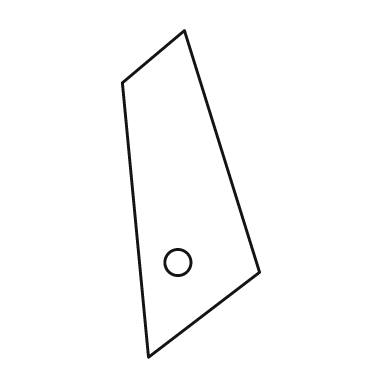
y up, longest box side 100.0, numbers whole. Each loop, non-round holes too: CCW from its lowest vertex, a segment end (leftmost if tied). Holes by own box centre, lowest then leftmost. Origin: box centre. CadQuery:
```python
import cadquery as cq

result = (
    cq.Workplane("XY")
    .moveTo(-13.0, -50.0)
    .lineTo(21.0, -24.0)
    .lineTo(-2.0, 50.0)
    .lineTo(-21.0, 34.0)
    .close()
    .moveTo(-4.0, -21.0)
    .circle(4.0)
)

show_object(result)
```